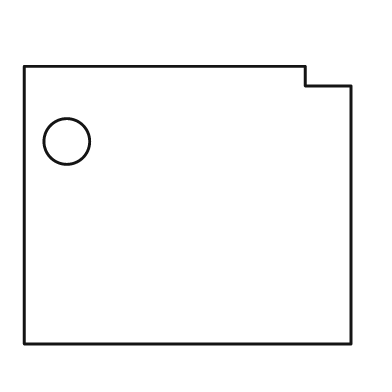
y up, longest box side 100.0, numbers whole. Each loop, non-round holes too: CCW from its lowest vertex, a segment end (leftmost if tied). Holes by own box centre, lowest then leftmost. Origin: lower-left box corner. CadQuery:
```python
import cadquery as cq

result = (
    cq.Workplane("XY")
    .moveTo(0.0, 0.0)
    .lineTo(100.0, 0.0)
    .lineTo(100.0, 79.0)
    .lineTo(86.0, 79.0)
    .lineTo(86.0, 85.0)
    .lineTo(0.0, 85.0)
    .close()
    .moveTo(13.0, 62.0)
    .circle(7.0)
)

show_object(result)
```